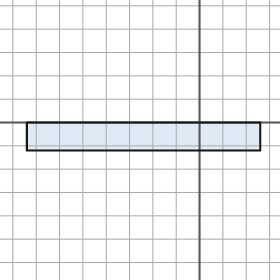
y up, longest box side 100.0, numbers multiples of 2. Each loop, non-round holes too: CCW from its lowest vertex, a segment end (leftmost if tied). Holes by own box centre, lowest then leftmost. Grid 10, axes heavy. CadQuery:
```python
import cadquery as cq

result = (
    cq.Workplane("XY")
    .moveTo(-74.0, -12.0)
    .lineTo(26.0, -12.0)
    .lineTo(26.0, 0.0)
    .lineTo(-74.0, 0.0)
    .close()
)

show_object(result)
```